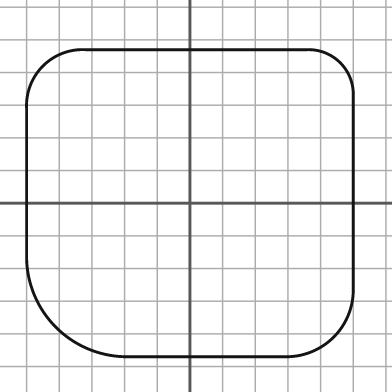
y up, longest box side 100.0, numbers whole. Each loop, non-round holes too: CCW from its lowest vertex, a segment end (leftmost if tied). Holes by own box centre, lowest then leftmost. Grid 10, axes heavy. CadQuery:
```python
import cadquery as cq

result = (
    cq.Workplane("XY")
    .moveTo(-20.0, -47.0)
    .lineTo(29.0, -47.0)
    .threePointArc((44.0, -41.0), (50.0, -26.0))
    .lineTo(50.0, 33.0)
    .threePointArc((46.0, 43.0), (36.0, 47.0))
    .lineTo(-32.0, 47.0)
    .threePointArc((-45.0, 42.0), (-50.0, 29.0))
    .lineTo(-50.0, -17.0)
    .threePointArc((-41.0, -38.0), (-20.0, -47.0))
    .close()
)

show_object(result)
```